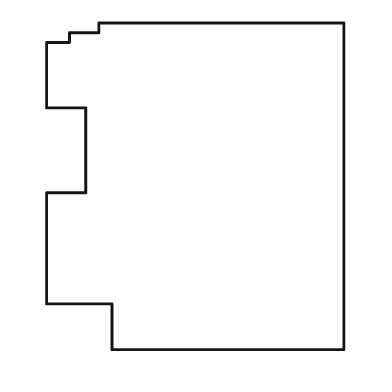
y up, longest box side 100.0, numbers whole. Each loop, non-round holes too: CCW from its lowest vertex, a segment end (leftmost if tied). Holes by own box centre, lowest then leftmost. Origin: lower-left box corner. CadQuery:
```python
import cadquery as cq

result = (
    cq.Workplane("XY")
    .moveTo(20.0, 0.0)
    .lineTo(91.0, 0.0)
    .lineTo(91.0, 100.0)
    .lineTo(16.0, 100.0)
    .lineTo(16.0, 97.0)
    .lineTo(7.0, 97.0)
    .lineTo(7.0, 94.0)
    .lineTo(0.0, 94.0)
    .lineTo(0.0, 74.0)
    .lineTo(12.0, 74.0)
    .lineTo(12.0, 48.0)
    .lineTo(0.0, 48.0)
    .lineTo(0.0, 14.0)
    .lineTo(20.0, 14.0)
    .close()
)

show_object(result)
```